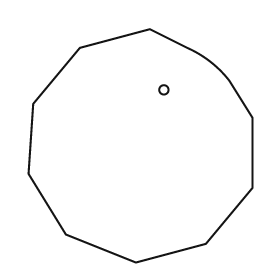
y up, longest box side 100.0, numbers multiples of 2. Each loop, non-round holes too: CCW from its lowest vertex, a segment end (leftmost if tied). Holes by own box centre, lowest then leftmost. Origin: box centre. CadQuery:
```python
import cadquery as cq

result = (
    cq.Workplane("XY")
    .moveTo(-2.0, -50.0)
    .lineTo(28.0, -42.0)
    .lineTo(48.0, -18.0)
    .lineTo(48.0, 12.0)
    .lineTo(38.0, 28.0)
    .threePointArc((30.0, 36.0), (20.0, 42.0))
    .lineTo(4.0, 50.0)
    .lineTo(-26.0, 42.0)
    .lineTo(-46.0, 18.0)
    .lineTo(-48.0, -12.0)
    .lineTo(-32.0, -38.0)
    .close()
    .moveTo(10.0, 24.0)
    .circle(2.0)
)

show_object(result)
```